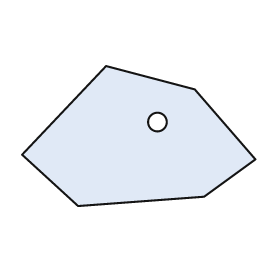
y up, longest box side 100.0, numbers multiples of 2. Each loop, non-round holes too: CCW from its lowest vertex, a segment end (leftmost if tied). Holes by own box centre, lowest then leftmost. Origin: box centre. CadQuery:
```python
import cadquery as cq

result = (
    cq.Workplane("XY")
    .moveTo(-26.0, -30.0)
    .lineTo(28.0, -26.0)
    .lineTo(50.0, -10.0)
    .lineTo(24.0, 20.0)
    .lineTo(-14.0, 30.0)
    .lineTo(-50.0, -8.0)
    .close()
    .moveTo(8.0, 6.0)
    .circle(4.0)
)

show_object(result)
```